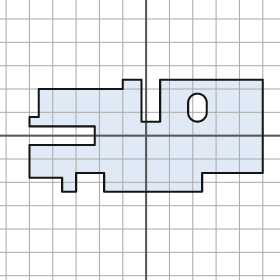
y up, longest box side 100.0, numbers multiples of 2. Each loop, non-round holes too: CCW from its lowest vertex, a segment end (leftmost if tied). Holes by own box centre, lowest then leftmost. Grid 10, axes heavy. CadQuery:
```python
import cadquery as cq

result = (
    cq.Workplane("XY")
    .moveTo(-36.0, -24.0)
    .lineTo(-30.0, -24.0)
    .lineTo(-30.0, -16.0)
    .lineTo(-18.0, -16.0)
    .lineTo(-18.0, -24.0)
    .lineTo(24.0, -24.0)
    .lineTo(24.0, -16.0)
    .lineTo(50.0, -16.0)
    .lineTo(50.0, 24.0)
    .lineTo(6.0, 24.0)
    .lineTo(6.0, 6.0)
    .lineTo(-2.0, 6.0)
    .lineTo(-2.0, 24.0)
    .lineTo(-10.0, 24.0)
    .lineTo(-10.0, 20.0)
    .lineTo(-46.0, 20.0)
    .lineTo(-46.0, 8.0)
    .lineTo(-50.0, 8.0)
    .lineTo(-50.0, 4.0)
    .lineTo(-22.0, 4.0)
    .lineTo(-22.0, -4.0)
    .lineTo(-50.0, -4.0)
    .lineTo(-50.0, -18.0)
    .lineTo(-36.0, -18.0)
    .close()
    .moveTo(18.0, 10.0)
    .threePointArc((22.0, 6.0), (26.0, 10.0))
    .lineTo(26.0, 14.0)
    .threePointArc((22.0, 18.0), (18.0, 14.0))
    .close()
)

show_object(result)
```